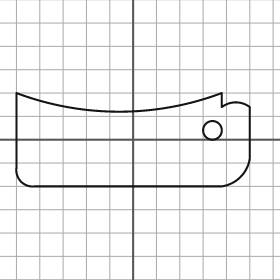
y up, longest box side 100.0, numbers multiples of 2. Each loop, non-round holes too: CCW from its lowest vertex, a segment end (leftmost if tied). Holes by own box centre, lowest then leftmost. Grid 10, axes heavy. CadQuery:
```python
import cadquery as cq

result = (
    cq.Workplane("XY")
    .moveTo(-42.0, -20.0)
    .lineTo(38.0, -20.0)
    .threePointArc((46.0, -16.0), (50.0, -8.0))
    .lineTo(50.0, 14.0)
    .threePointArc((44.0, 16.0), (38.0, 14.0))
    .lineTo(38.0, 20.0)
    .threePointArc((-6.0, 12.0), (-50.0, 20.0))
    .lineTo(-50.0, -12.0)
    .threePointArc((-48.0, -18.0), (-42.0, -20.0))
    .close()
    .moveTo(34.0, 4.0)
    .circle(4.0)
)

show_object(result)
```